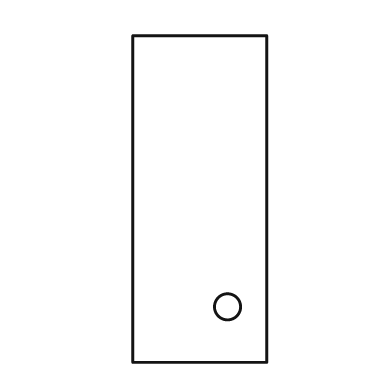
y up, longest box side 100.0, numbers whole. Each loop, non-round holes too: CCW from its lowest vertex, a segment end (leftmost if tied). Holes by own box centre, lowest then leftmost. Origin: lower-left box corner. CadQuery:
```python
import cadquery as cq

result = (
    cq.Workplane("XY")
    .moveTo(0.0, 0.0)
    .lineTo(41.0, 0.0)
    .lineTo(41.0, 100.0)
    .lineTo(0.0, 100.0)
    .close()
    .moveTo(29.0, 17.0)
    .circle(4.0)
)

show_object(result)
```